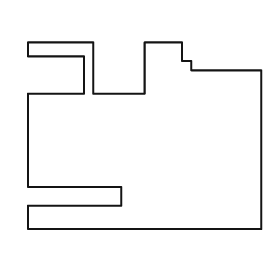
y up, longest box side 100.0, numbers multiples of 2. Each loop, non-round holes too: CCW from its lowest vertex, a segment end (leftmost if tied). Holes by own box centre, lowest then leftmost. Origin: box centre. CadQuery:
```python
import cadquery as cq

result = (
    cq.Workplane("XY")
    .moveTo(-50.0, -40.0)
    .lineTo(50.0, -40.0)
    .lineTo(50.0, 28.0)
    .lineTo(20.0, 28.0)
    .lineTo(20.0, 32.0)
    .lineTo(16.0, 32.0)
    .lineTo(16.0, 40.0)
    .lineTo(0.0, 40.0)
    .lineTo(0.0, 18.0)
    .lineTo(-22.0, 18.0)
    .lineTo(-22.0, 40.0)
    .lineTo(-50.0, 40.0)
    .lineTo(-50.0, 34.0)
    .lineTo(-26.0, 34.0)
    .lineTo(-26.0, 18.0)
    .lineTo(-50.0, 18.0)
    .lineTo(-50.0, -22.0)
    .lineTo(-10.0, -22.0)
    .lineTo(-10.0, -30.0)
    .lineTo(-50.0, -30.0)
    .close()
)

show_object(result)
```